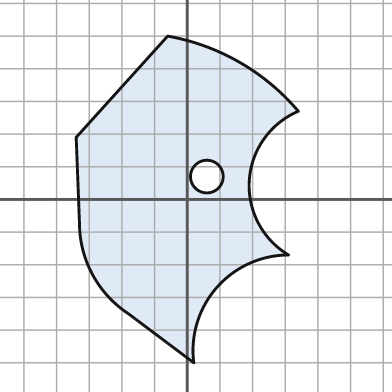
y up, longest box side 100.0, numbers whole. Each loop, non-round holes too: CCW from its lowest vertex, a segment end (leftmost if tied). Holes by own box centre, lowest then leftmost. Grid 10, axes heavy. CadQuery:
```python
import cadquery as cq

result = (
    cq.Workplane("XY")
    .moveTo(2.0, -50.0)
    .threePointArc((9.0, -27.0), (31.0, -17.0))
    .threePointArc((19.0, 6.0), (34.0, 27.0))
    .threePointArc((16.0, 42.0), (-6.0, 50.0))
    .lineTo(-34.0, 19.0)
    .lineTo(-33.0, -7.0)
    .threePointArc((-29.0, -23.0), (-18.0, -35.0))
    .close()
    .moveTo(6.0, 7.0)
    .circle(5.0)
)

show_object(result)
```